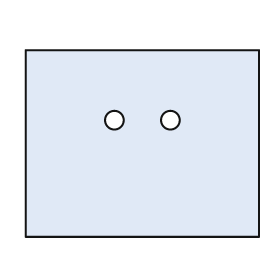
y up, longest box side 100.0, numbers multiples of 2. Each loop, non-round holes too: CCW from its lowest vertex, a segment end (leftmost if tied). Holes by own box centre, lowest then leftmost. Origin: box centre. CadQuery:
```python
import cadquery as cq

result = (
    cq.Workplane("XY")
    .moveTo(-50.0, -40.0)
    .lineTo(50.0, -40.0)
    .lineTo(50.0, 40.0)
    .lineTo(-50.0, 40.0)
    .close()
    .moveTo(-12.0, 10.0)
    .circle(4.0)
    .moveTo(12.0, 10.0)
    .circle(4.0)
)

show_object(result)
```